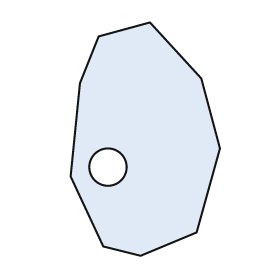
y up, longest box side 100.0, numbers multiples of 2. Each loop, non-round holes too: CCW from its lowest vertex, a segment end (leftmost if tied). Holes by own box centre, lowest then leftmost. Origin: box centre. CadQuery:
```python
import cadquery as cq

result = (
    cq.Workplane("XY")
    .moveTo(-2.0, -50.0)
    .lineTo(22.0, -40.0)
    .lineTo(32.0, -4.0)
    .lineTo(24.0, 26.0)
    .lineTo(2.0, 50.0)
    .lineTo(-20.0, 44.0)
    .lineTo(-28.0, 24.0)
    .lineTo(-32.0, -16.0)
    .lineTo(-18.0, -46.0)
    .close()
    .moveTo(-16.0, -12.0)
    .circle(8.0)
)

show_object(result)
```